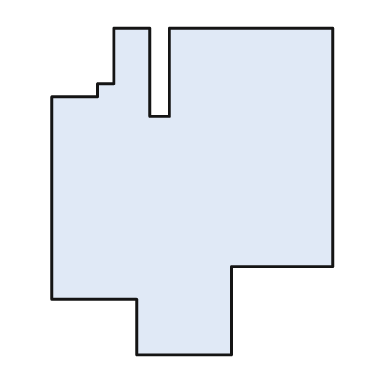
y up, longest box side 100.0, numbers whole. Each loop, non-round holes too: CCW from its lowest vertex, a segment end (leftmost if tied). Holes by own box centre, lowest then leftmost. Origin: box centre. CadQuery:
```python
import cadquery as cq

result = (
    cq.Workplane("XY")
    .moveTo(-17.0, -50.0)
    .lineTo(12.0, -50.0)
    .lineTo(12.0, -23.0)
    .lineTo(43.0, -23.0)
    .lineTo(43.0, 50.0)
    .lineTo(-7.0, 50.0)
    .lineTo(-7.0, 23.0)
    .lineTo(-13.0, 23.0)
    .lineTo(-13.0, 50.0)
    .lineTo(-24.0, 50.0)
    .lineTo(-24.0, 33.0)
    .lineTo(-29.0, 33.0)
    .lineTo(-29.0, 29.0)
    .lineTo(-43.0, 29.0)
    .lineTo(-43.0, -33.0)
    .lineTo(-17.0, -33.0)
    .close()
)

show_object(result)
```